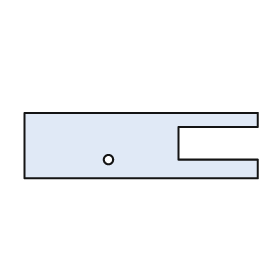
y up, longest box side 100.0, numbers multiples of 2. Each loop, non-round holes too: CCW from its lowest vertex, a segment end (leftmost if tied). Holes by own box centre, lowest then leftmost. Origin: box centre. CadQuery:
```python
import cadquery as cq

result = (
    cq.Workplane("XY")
    .moveTo(-50.0, -14.0)
    .lineTo(50.0, -14.0)
    .lineTo(50.0, -6.0)
    .lineTo(16.0, -6.0)
    .lineTo(16.0, 8.0)
    .lineTo(50.0, 8.0)
    .lineTo(50.0, 14.0)
    .lineTo(-50.0, 14.0)
    .close()
    .moveTo(-14.0, -6.0)
    .circle(2.0)
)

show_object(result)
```